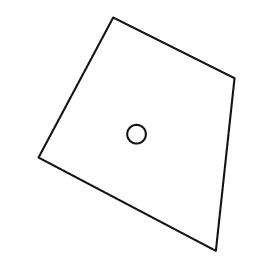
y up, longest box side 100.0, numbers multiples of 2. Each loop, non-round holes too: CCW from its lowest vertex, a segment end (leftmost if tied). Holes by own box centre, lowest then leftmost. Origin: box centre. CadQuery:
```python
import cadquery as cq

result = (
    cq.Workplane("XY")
    .moveTo(34.0, -50.0)
    .lineTo(42.0, 24.0)
    .lineTo(-10.0, 50.0)
    .lineTo(-42.0, -10.0)
    .close()
    .moveTo(0.0, 0.0)
    .circle(4.0)
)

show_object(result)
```